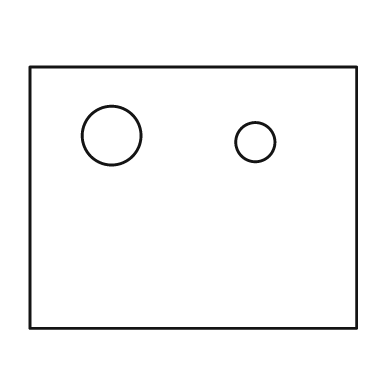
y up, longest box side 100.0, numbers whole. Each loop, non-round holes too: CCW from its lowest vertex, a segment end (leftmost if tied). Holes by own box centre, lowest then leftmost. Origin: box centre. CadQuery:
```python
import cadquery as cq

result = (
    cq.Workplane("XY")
    .moveTo(-50.0, -40.0)
    .lineTo(50.0, -40.0)
    .lineTo(50.0, 40.0)
    .lineTo(-50.0, 40.0)
    .close()
    .moveTo(19.0, 17.0)
    .circle(6.0)
    .moveTo(-25.0, 19.0)
    .circle(9.0)
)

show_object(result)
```